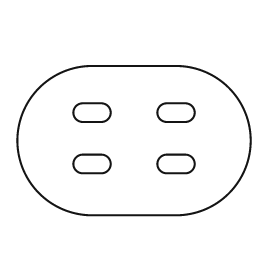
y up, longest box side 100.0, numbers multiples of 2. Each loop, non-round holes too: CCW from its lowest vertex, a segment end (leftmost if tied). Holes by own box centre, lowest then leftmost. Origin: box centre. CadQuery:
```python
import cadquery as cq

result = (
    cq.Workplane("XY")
    .moveTo(-18.0, -32.0)
    .lineTo(18.0, -32.0)
    .threePointArc((50.0, 0.0), (18.0, 32.0))
    .lineTo(-18.0, 32.0)
    .threePointArc((-50.0, 0.0), (-18.0, -32.0))
    .close()
    .moveTo(-22.0, -14.0)
    .lineTo(-14.0, -14.0)
    .threePointArc((-10.0, -10.0), (-14.0, -6.0))
    .lineTo(-22.0, -6.0)
    .threePointArc((-26.0, -10.0), (-22.0, -14.0))
    .close()
    .moveTo(14.0, -14.0)
    .lineTo(22.0, -14.0)
    .threePointArc((26.0, -10.0), (22.0, -6.0))
    .lineTo(14.0, -6.0)
    .threePointArc((10.0, -10.0), (14.0, -14.0))
    .close()
    .moveTo(-22.0, 8.0)
    .lineTo(-14.0, 8.0)
    .threePointArc((-10.0, 12.0), (-14.0, 16.0))
    .lineTo(-22.0, 16.0)
    .threePointArc((-26.0, 12.0), (-22.0, 8.0))
    .close()
    .moveTo(14.0, 8.0)
    .lineTo(22.0, 8.0)
    .threePointArc((26.0, 12.0), (22.0, 16.0))
    .lineTo(14.0, 16.0)
    .threePointArc((10.0, 12.0), (14.0, 8.0))
    .close()
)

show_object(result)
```